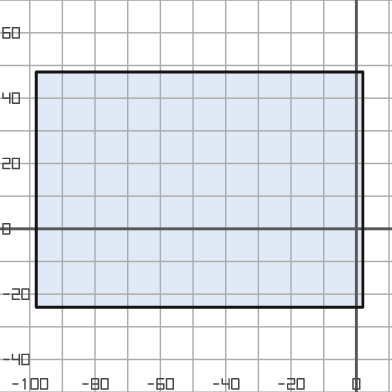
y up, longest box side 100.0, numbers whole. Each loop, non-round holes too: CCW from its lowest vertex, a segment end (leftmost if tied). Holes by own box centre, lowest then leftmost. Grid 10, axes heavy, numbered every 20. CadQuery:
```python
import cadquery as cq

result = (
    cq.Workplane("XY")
    .moveTo(-98.0, -24.0)
    .lineTo(2.0, -24.0)
    .lineTo(2.0, 48.0)
    .lineTo(-98.0, 48.0)
    .close()
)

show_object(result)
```